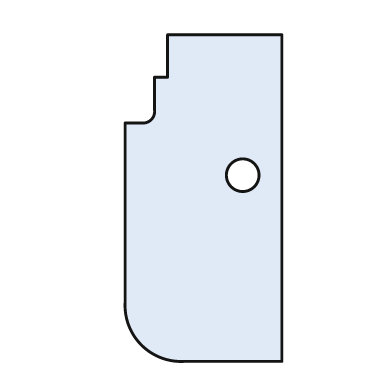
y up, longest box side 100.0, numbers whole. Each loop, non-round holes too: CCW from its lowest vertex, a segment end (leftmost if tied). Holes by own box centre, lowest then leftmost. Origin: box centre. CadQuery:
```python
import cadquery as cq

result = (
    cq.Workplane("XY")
    .moveTo(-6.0, -50.0)
    .lineTo(24.0, -50.0)
    .lineTo(24.0, 50.0)
    .lineTo(-11.0, 50.0)
    .lineTo(-11.0, 37.0)
    .lineTo(-15.0, 37.0)
    .lineTo(-15.0, 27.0)
    .threePointArc((-16.0, 24.0), (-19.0, 23.0))
    .lineTo(-24.0, 23.0)
    .lineTo(-24.0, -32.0)
    .threePointArc((-19.0, -45.0), (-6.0, -50.0))
    .close()
    .moveTo(12.0, 7.0)
    .circle(5.0)
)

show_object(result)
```